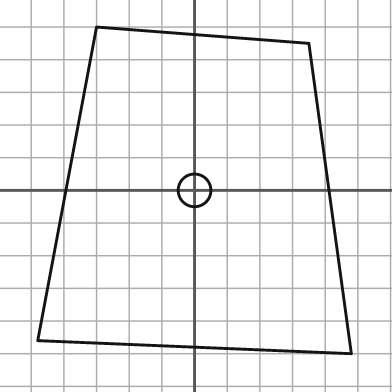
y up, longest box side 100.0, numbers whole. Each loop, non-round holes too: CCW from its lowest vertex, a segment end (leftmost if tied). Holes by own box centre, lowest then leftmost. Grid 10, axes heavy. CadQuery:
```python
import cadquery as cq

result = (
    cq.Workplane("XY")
    .moveTo(48.0, -50.0)
    .lineTo(35.0, 45.0)
    .lineTo(-30.0, 50.0)
    .lineTo(-48.0, -46.0)
    .close()
    .moveTo(0.0, 0.0)
    .circle(5.0)
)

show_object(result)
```